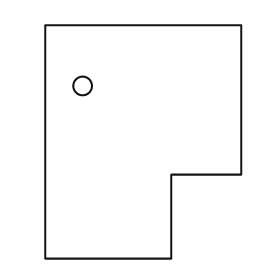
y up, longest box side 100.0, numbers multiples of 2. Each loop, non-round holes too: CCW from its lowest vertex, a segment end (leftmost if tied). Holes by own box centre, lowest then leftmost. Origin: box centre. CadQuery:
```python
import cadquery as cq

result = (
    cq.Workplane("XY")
    .moveTo(-42.0, -50.0)
    .lineTo(12.0, -50.0)
    .lineTo(12.0, -14.0)
    .lineTo(42.0, -14.0)
    .lineTo(42.0, 50.0)
    .lineTo(-42.0, 50.0)
    .close()
    .moveTo(-26.0, 24.0)
    .circle(4.0)
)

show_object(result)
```